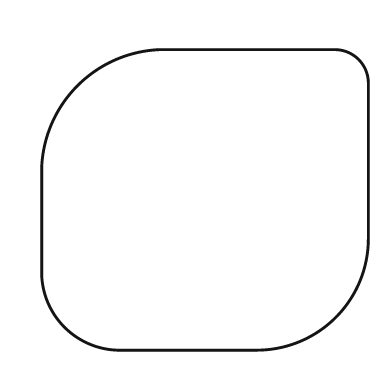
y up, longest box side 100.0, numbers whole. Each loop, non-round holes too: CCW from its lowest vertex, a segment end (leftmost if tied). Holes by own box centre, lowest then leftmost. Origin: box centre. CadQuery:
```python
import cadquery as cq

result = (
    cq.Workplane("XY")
    .moveTo(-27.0, -46.0)
    .lineTo(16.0, -46.0)
    .threePointArc((40.0, -36.0), (50.0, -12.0))
    .lineTo(50.0, 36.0)
    .threePointArc((47.0, 43.0), (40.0, 46.0))
    .lineTo(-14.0, 46.0)
    .threePointArc((-39.0, 35.0), (-50.0, 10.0))
    .lineTo(-50.0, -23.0)
    .threePointArc((-43.0, -39.0), (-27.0, -46.0))
    .close()
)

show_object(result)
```